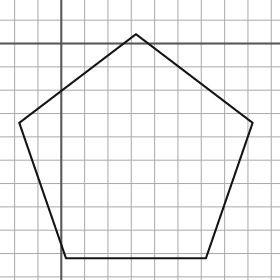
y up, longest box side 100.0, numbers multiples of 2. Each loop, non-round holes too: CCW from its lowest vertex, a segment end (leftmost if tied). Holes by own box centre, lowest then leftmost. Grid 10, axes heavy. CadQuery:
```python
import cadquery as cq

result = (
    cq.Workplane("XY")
    .moveTo(2.0, -92.0)
    .lineTo(62.0, -92.0)
    .lineTo(82.0, -34.0)
    .lineTo(32.0, 4.0)
    .lineTo(-18.0, -34.0)
    .close()
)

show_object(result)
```